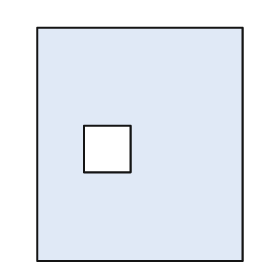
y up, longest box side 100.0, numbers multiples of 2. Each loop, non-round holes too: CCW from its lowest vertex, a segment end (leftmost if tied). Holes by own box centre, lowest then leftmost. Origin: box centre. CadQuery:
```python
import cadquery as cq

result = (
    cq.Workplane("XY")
    .moveTo(-44.0, -50.0)
    .lineTo(44.0, -50.0)
    .lineTo(44.0, 50.0)
    .lineTo(-44.0, 50.0)
    .close()
    .moveTo(-24.0, -12.0)
    .lineTo(-4.0, -12.0)
    .lineTo(-4.0, 8.0)
    .lineTo(-24.0, 8.0)
    .close()
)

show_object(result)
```